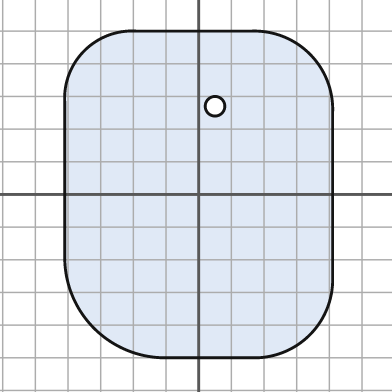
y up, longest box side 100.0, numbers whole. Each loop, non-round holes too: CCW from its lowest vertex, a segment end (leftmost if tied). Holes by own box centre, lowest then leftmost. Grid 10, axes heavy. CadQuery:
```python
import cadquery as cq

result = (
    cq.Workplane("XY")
    .moveTo(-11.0, -50.0)
    .lineTo(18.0, -50.0)
    .threePointArc((34.0, -43.0), (41.0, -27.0))
    .lineTo(41.0, 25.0)
    .threePointArc((34.0, 43.0), (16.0, 50.0))
    .lineTo(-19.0, 50.0)
    .threePointArc((-35.0, 44.0), (-41.0, 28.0))
    .lineTo(-41.0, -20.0)
    .threePointArc((-32.0, -41.0), (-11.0, -50.0))
    .close()
    .moveTo(5.0, 27.0)
    .circle(3.0)
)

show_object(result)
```